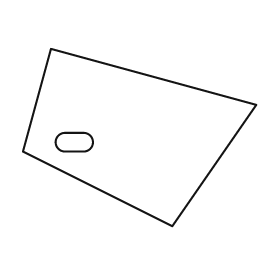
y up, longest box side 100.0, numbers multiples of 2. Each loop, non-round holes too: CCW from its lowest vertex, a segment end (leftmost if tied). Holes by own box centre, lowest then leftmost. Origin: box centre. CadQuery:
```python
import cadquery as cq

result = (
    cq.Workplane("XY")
    .moveTo(14.0, -38.0)
    .lineTo(50.0, 14.0)
    .lineTo(-38.0, 38.0)
    .lineTo(-50.0, -6.0)
    .close()
    .moveTo(-32.0, -6.0)
    .lineTo(-24.0, -6.0)
    .threePointArc((-20.0, -2.0), (-24.0, 2.0))
    .lineTo(-32.0, 2.0)
    .threePointArc((-36.0, -2.0), (-32.0, -6.0))
    .close()
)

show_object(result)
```